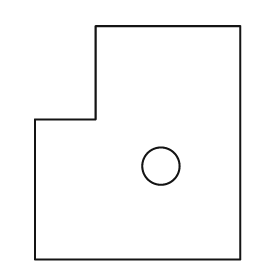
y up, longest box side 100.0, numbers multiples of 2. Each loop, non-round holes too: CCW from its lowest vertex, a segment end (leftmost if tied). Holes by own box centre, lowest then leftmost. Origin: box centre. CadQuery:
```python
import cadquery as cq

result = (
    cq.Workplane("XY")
    .moveTo(-44.0, -50.0)
    .lineTo(44.0, -50.0)
    .lineTo(44.0, 50.0)
    .lineTo(-18.0, 50.0)
    .lineTo(-18.0, 10.0)
    .lineTo(-44.0, 10.0)
    .close()
    .moveTo(10.0, -10.0)
    .circle(8.0)
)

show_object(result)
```